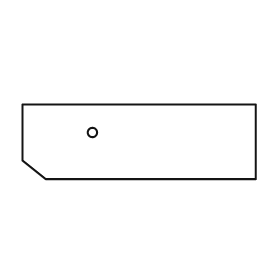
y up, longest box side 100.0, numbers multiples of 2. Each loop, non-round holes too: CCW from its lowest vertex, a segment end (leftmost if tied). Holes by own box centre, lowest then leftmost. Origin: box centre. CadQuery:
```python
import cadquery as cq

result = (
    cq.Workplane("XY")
    .moveTo(-40.0, -16.0)
    .lineTo(50.0, -16.0)
    .lineTo(50.0, 16.0)
    .lineTo(-50.0, 16.0)
    .lineTo(-50.0, -8.0)
    .close()
    .moveTo(-20.0, 4.0)
    .circle(2.0)
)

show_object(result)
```